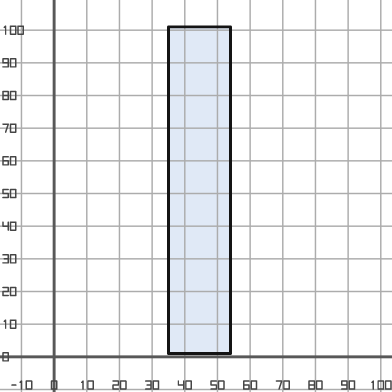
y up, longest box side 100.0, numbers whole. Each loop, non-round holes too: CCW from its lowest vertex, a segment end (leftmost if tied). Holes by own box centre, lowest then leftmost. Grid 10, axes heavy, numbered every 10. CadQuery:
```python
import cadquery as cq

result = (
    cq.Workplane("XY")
    .moveTo(35.0, 1.0)
    .lineTo(54.0, 1.0)
    .lineTo(54.0, 101.0)
    .lineTo(35.0, 101.0)
    .close()
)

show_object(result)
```